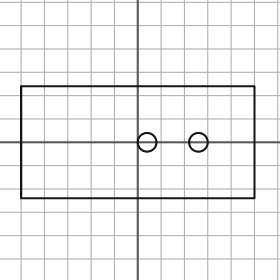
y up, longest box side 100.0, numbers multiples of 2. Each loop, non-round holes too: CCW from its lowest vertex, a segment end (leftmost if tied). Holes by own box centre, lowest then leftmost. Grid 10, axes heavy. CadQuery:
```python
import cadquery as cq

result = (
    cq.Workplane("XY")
    .moveTo(-50.0, -24.0)
    .lineTo(50.0, -24.0)
    .lineTo(50.0, 24.0)
    .lineTo(-50.0, 24.0)
    .close()
    .moveTo(4.0, 0.0)
    .circle(4.0)
    .moveTo(26.0, 0.0)
    .circle(4.0)
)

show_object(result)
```